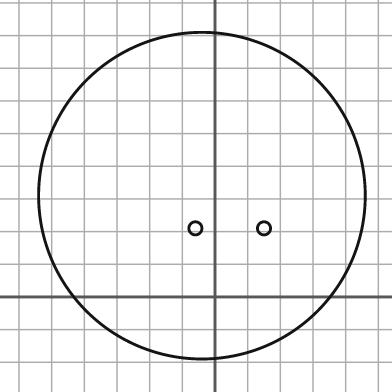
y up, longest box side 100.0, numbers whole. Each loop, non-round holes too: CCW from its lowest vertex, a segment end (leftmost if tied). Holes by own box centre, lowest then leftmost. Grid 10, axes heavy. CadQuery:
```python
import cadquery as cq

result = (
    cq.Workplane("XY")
    .moveTo(-4.0, 31.0)
    .circle(50.0)
    .moveTo(-6.0, 21.0)
    .circle(2.0)
    .moveTo(15.0, 21.0)
    .circle(2.0)
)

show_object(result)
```